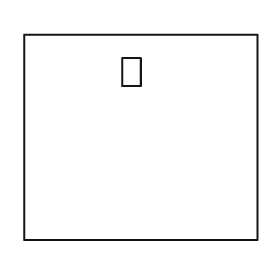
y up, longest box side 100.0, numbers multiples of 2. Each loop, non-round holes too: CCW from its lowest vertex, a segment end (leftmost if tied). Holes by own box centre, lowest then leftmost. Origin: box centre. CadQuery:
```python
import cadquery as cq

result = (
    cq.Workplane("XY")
    .moveTo(-50.0, -44.0)
    .lineTo(50.0, -44.0)
    .lineTo(50.0, 44.0)
    .lineTo(-50.0, 44.0)
    .close()
    .moveTo(-8.0, 22.0)
    .lineTo(0.0, 22.0)
    .lineTo(0.0, 34.0)
    .lineTo(-8.0, 34.0)
    .close()
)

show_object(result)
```